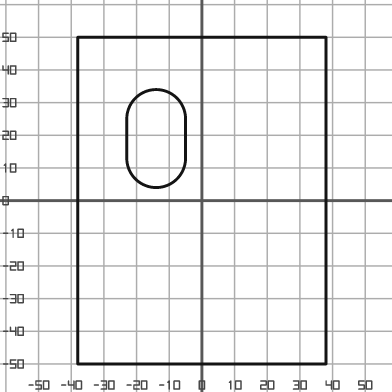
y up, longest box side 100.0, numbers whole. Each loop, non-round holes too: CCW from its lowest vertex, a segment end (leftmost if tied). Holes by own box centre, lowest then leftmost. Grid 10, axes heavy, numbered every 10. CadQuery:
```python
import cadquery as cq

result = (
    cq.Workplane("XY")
    .moveTo(-38.0, -50.0)
    .lineTo(38.0, -50.0)
    .lineTo(38.0, 50.0)
    .lineTo(-38.0, 50.0)
    .close()
    .moveTo(-23.0, 13.0)
    .threePointArc((-14.0, 4.0), (-5.0, 13.0))
    .lineTo(-5.0, 25.0)
    .threePointArc((-14.0, 34.0), (-23.0, 25.0))
    .close()
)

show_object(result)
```